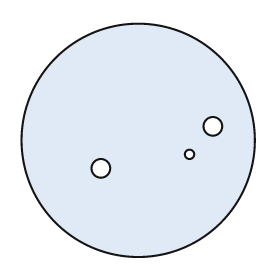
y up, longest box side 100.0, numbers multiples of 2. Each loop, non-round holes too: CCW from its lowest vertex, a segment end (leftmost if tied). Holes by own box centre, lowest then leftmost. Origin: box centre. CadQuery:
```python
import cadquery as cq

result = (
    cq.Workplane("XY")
    .moveTo(0.0, 0.0)
    .circle(50.0)
    .moveTo(-16.0, -12.0)
    .circle(4.0)
    .moveTo(22.0, -6.0)
    .circle(2.0)
    .moveTo(32.0, 6.0)
    .circle(4.0)
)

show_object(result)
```